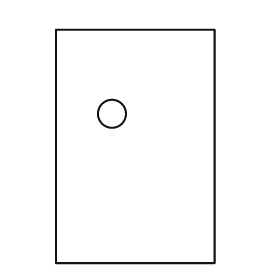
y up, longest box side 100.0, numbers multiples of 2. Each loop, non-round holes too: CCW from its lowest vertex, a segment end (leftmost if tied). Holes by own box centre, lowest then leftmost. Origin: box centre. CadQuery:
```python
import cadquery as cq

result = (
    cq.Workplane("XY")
    .moveTo(-34.0, -50.0)
    .lineTo(34.0, -50.0)
    .lineTo(34.0, 50.0)
    .lineTo(-34.0, 50.0)
    .close()
    .moveTo(-10.0, 14.0)
    .circle(6.0)
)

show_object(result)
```